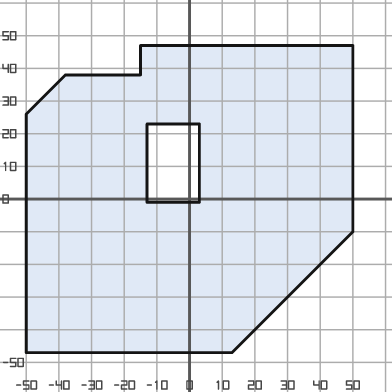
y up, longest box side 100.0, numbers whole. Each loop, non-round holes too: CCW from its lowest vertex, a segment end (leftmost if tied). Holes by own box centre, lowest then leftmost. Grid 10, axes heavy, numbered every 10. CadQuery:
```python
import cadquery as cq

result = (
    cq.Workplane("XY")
    .moveTo(-50.0, -47.0)
    .lineTo(13.0, -47.0)
    .lineTo(50.0, -10.0)
    .lineTo(50.0, 47.0)
    .lineTo(-15.0, 47.0)
    .lineTo(-15.0, 38.0)
    .lineTo(-38.0, 38.0)
    .lineTo(-50.0, 26.0)
    .close()
    .moveTo(-13.0, -1.0)
    .lineTo(3.0, -1.0)
    .lineTo(3.0, 23.0)
    .lineTo(-13.0, 23.0)
    .close()
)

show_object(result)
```